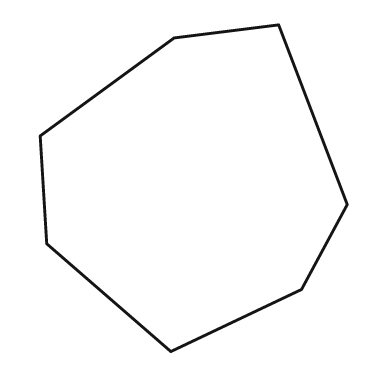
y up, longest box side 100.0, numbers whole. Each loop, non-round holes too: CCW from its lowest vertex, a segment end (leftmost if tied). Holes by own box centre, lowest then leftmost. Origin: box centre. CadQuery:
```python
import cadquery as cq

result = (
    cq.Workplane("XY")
    .moveTo(-7.0, -50.0)
    .lineTo(33.0, -31.0)
    .lineTo(47.0, -5.0)
    .lineTo(26.0, 50.0)
    .lineTo(-6.0, 46.0)
    .lineTo(-47.0, 16.0)
    .lineTo(-45.0, -17.0)
    .close()
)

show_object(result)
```